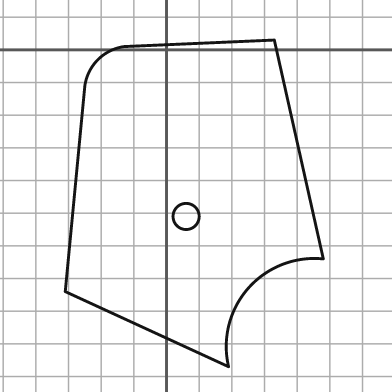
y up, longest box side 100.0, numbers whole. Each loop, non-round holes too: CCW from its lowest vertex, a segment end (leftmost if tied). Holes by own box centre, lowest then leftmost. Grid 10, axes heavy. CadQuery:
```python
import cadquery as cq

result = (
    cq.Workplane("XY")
    .moveTo(19.0, -97.0)
    .threePointArc((25.0, -73.0), (48.0, -64.0))
    .lineTo(33.0, 3.0)
    .lineTo(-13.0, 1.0)
    .threePointArc((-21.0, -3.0), (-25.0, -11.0))
    .lineTo(-31.0, -74.0)
    .close()
    .moveTo(6.0, -51.0)
    .circle(4.0)
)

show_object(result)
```